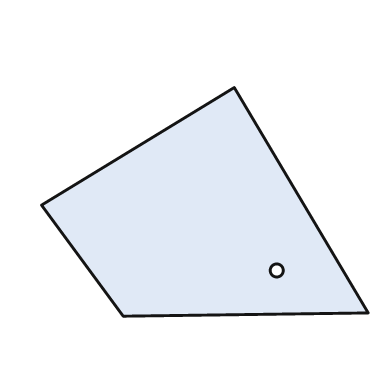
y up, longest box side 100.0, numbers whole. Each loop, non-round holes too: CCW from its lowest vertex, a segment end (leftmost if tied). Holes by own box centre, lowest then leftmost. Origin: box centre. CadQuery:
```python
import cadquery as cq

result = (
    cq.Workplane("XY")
    .moveTo(-25.0, -35.0)
    .lineTo(50.0, -34.0)
    .lineTo(9.0, 35.0)
    .lineTo(-50.0, -1.0)
    .close()
    .moveTo(22.0, -21.0)
    .circle(2.0)
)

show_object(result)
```